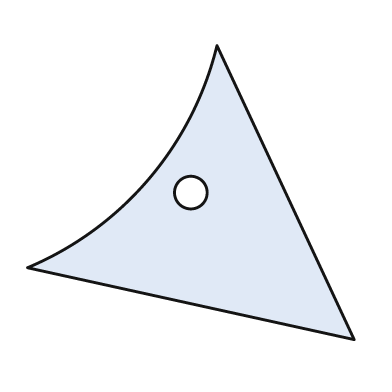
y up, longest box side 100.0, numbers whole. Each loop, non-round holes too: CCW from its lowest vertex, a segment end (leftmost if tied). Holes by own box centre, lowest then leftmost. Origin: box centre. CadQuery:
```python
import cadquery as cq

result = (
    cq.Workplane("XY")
    .moveTo(50.0, -45.0)
    .lineTo(8.0, 45.0)
    .threePointArc((-13.0, 4.0), (-50.0, -23.0))
    .close()
    .moveTo(0.0, 0.0)
    .circle(5.0)
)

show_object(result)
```